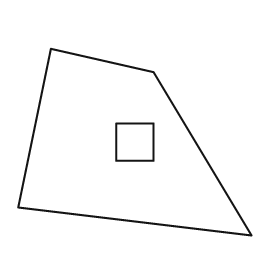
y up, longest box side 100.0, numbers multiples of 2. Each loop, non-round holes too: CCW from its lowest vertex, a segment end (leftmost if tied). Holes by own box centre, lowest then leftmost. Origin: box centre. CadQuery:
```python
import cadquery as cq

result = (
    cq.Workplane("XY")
    .moveTo(50.0, -40.0)
    .lineTo(8.0, 30.0)
    .lineTo(-36.0, 40.0)
    .lineTo(-50.0, -28.0)
    .close()
    .moveTo(-8.0, -8.0)
    .lineTo(8.0, -8.0)
    .lineTo(8.0, 8.0)
    .lineTo(-8.0, 8.0)
    .close()
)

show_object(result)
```